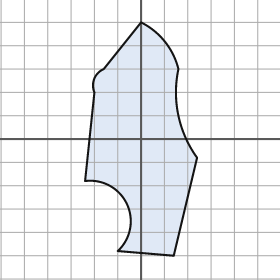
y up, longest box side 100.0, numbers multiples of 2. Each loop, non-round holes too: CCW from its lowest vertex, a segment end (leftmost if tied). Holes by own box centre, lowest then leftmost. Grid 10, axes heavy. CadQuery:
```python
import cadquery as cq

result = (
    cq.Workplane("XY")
    .moveTo(14.0, -50.0)
    .lineTo(24.0, -8.0)
    .threePointArc((16.0, 10.0), (16.0, 30.0))
    .threePointArc((10.0, 42.0), (0.0, 50.0))
    .lineTo(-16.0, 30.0)
    .threePointArc((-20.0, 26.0), (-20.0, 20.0))
    .lineTo(-24.0, -18.0)
    .threePointArc((-6.0, -28.0), (-10.0, -48.0))
    .close()
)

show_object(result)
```